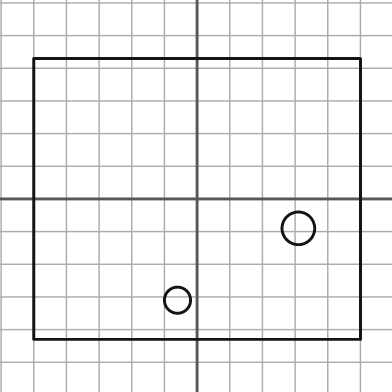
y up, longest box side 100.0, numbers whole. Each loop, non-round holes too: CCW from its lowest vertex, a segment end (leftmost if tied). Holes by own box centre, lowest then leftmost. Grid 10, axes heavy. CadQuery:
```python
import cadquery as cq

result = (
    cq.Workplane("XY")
    .moveTo(-50.0, -43.0)
    .lineTo(50.0, -43.0)
    .lineTo(50.0, 43.0)
    .lineTo(-50.0, 43.0)
    .close()
    .moveTo(-6.0, -31.0)
    .circle(4.0)
    .moveTo(31.0, -9.0)
    .circle(5.0)
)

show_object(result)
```